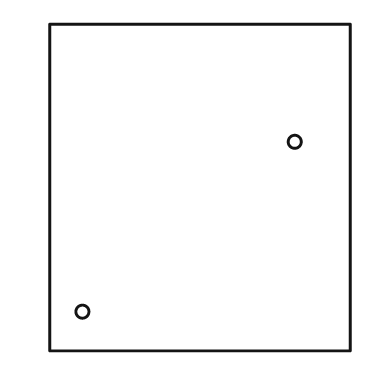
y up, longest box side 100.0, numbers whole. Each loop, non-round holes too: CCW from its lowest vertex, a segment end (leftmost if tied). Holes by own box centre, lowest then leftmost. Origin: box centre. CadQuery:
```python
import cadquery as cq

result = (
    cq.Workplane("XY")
    .moveTo(-46.0, -50.0)
    .lineTo(46.0, -50.0)
    .lineTo(46.0, 50.0)
    .lineTo(-46.0, 50.0)
    .close()
    .moveTo(-36.0, -38.0)
    .circle(2.0)
    .moveTo(29.0, 14.0)
    .circle(2.0)
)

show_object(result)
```